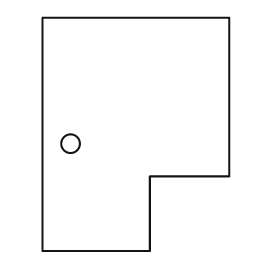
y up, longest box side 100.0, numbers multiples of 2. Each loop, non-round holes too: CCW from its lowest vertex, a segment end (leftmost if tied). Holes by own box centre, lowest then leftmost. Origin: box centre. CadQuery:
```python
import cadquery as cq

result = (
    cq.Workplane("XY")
    .moveTo(-40.0, -50.0)
    .lineTo(6.0, -50.0)
    .lineTo(6.0, -18.0)
    .lineTo(40.0, -18.0)
    .lineTo(40.0, 50.0)
    .lineTo(-40.0, 50.0)
    .close()
    .moveTo(-28.0, -4.0)
    .circle(4.0)
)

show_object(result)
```